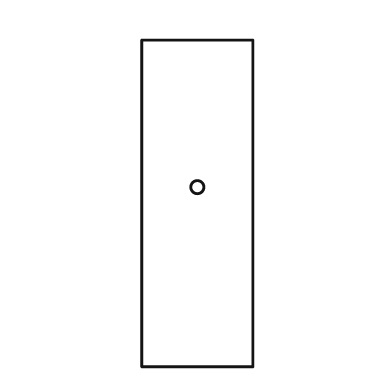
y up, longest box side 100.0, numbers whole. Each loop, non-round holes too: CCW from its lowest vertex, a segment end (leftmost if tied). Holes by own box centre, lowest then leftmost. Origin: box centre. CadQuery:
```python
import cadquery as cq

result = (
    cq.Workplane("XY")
    .moveTo(-17.0, -50.0)
    .lineTo(17.0, -50.0)
    .lineTo(17.0, 50.0)
    .lineTo(-17.0, 50.0)
    .close()
    .moveTo(0.0, 5.0)
    .circle(2.0)
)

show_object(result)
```